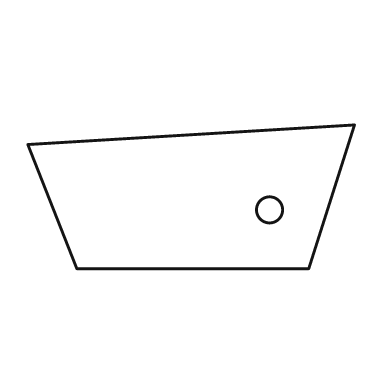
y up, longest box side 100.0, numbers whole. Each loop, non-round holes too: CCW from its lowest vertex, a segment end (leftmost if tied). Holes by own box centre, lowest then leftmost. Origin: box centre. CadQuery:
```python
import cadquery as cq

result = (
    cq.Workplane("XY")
    .moveTo(-35.0, -22.0)
    .lineTo(36.0, -22.0)
    .lineTo(50.0, 22.0)
    .lineTo(-50.0, 16.0)
    .close()
    .moveTo(24.0, -4.0)
    .circle(4.0)
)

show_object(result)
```